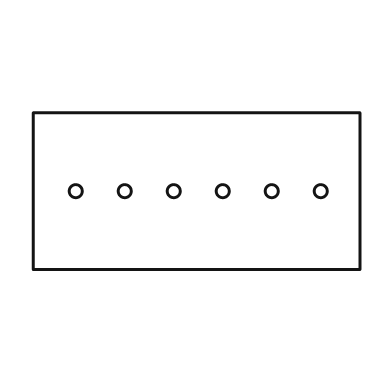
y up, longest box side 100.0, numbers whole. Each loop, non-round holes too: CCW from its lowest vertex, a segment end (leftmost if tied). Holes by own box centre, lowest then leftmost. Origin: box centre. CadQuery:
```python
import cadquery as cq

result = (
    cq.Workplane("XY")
    .moveTo(-50.0, -24.0)
    .lineTo(50.0, -24.0)
    .lineTo(50.0, 24.0)
    .lineTo(-50.0, 24.0)
    .close()
    .moveTo(-37.0, 0.0)
    .circle(2.0)
    .moveTo(-22.0, 0.0)
    .circle(2.0)
    .moveTo(-7.0, 0.0)
    .circle(2.0)
    .moveTo(8.0, 0.0)
    .circle(2.0)
    .moveTo(23.0, 0.0)
    .circle(2.0)
    .moveTo(38.0, 0.0)
    .circle(2.0)
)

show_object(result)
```